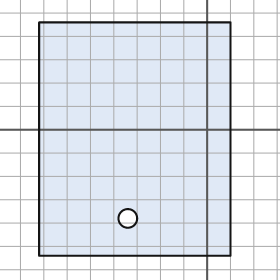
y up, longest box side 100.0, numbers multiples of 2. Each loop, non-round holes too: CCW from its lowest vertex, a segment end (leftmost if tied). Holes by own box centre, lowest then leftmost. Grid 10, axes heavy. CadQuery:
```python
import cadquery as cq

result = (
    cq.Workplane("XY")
    .moveTo(-72.0, -54.0)
    .lineTo(10.0, -54.0)
    .lineTo(10.0, 46.0)
    .lineTo(-72.0, 46.0)
    .close()
    .moveTo(-34.0, -38.0)
    .circle(4.0)
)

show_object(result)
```